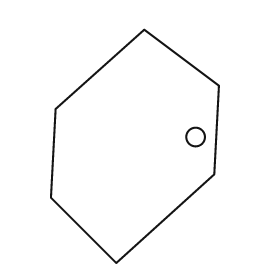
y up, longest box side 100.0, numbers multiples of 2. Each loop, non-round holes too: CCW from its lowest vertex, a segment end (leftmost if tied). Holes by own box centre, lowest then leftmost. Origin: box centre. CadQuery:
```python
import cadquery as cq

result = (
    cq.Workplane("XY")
    .moveTo(-8.0, -50.0)
    .lineTo(34.0, -12.0)
    .lineTo(36.0, 26.0)
    .lineTo(4.0, 50.0)
    .lineTo(-34.0, 16.0)
    .lineTo(-36.0, -22.0)
    .close()
    .moveTo(26.0, 4.0)
    .circle(4.0)
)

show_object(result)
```